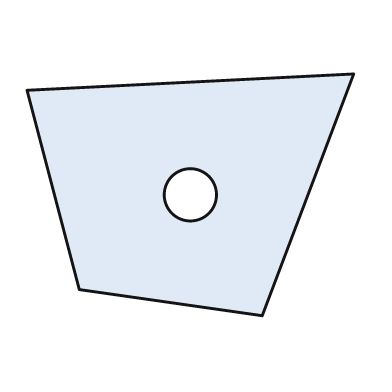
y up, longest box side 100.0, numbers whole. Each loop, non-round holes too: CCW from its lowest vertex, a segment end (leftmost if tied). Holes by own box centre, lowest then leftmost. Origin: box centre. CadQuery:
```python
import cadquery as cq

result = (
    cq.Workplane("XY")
    .moveTo(22.0, -37.0)
    .lineTo(50.0, 37.0)
    .lineTo(-50.0, 32.0)
    .lineTo(-34.0, -29.0)
    .close()
    .moveTo(0.0, 0.0)
    .circle(8.0)
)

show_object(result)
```